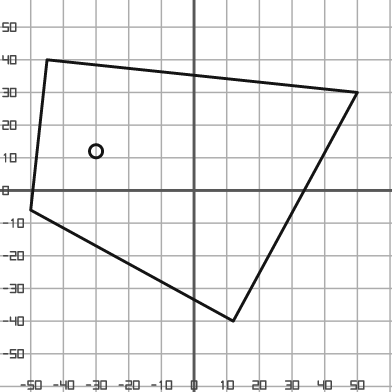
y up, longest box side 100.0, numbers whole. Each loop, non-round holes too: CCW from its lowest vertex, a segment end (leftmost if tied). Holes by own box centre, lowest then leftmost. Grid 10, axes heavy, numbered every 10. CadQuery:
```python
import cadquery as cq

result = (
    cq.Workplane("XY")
    .moveTo(12.0, -40.0)
    .lineTo(50.0, 30.0)
    .lineTo(-45.0, 40.0)
    .lineTo(-50.0, -6.0)
    .close()
    .moveTo(-30.0, 12.0)
    .circle(2.0)
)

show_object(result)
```